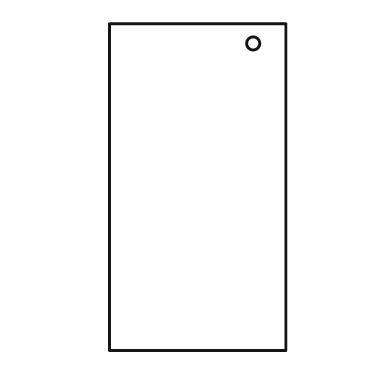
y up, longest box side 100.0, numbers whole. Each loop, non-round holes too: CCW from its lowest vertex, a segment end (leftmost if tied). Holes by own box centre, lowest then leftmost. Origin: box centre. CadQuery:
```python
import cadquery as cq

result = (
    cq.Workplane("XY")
    .moveTo(-27.0, -50.0)
    .lineTo(27.0, -50.0)
    .lineTo(27.0, 50.0)
    .lineTo(-27.0, 50.0)
    .close()
    .moveTo(17.0, 44.0)
    .circle(2.0)
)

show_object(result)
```